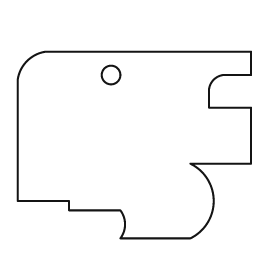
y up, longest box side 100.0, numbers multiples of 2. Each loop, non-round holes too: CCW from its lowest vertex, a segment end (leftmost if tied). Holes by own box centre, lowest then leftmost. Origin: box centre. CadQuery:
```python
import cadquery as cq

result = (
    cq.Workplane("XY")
    .moveTo(-6.0, -40.0)
    .lineTo(24.0, -40.0)
    .threePointArc((34.0, -24.0), (24.0, -8.0))
    .lineTo(50.0, -8.0)
    .lineTo(50.0, 16.0)
    .lineTo(32.0, 16.0)
    .lineTo(32.0, 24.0)
    .threePointArc((34.0, 28.0), (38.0, 30.0))
    .lineTo(50.0, 30.0)
    .lineTo(50.0, 40.0)
    .lineTo(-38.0, 40.0)
    .threePointArc((-46.0, 36.0), (-50.0, 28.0))
    .lineTo(-50.0, -24.0)
    .lineTo(-28.0, -24.0)
    .lineTo(-28.0, -28.0)
    .lineTo(-6.0, -28.0)
    .threePointArc((-4.0, -34.0), (-6.0, -40.0))
    .close()
    .moveTo(-10.0, 30.0)
    .circle(4.0)
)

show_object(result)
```